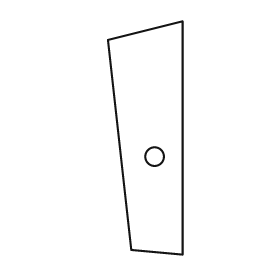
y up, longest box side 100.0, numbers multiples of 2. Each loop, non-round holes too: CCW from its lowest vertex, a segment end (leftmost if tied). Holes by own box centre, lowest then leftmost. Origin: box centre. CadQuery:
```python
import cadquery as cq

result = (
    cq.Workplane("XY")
    .moveTo(16.0, -50.0)
    .lineTo(16.0, 50.0)
    .lineTo(-16.0, 42.0)
    .lineTo(-6.0, -48.0)
    .close()
    .moveTo(4.0, -8.0)
    .circle(4.0)
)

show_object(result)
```